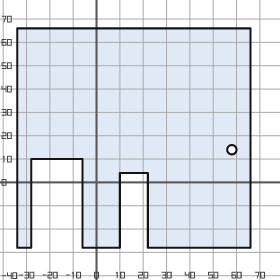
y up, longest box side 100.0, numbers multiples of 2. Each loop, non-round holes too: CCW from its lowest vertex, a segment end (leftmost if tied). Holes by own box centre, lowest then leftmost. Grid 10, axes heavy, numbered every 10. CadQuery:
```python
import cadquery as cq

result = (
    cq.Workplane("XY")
    .moveTo(-34.0, -28.0)
    .lineTo(-28.0, -28.0)
    .lineTo(-28.0, 10.0)
    .lineTo(-6.0, 10.0)
    .lineTo(-6.0, -28.0)
    .lineTo(10.0, -28.0)
    .lineTo(10.0, 4.0)
    .lineTo(22.0, 4.0)
    .lineTo(22.0, -28.0)
    .lineTo(66.0, -28.0)
    .lineTo(66.0, 66.0)
    .lineTo(-34.0, 66.0)
    .close()
    .moveTo(58.0, 14.0)
    .circle(2.0)
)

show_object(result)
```